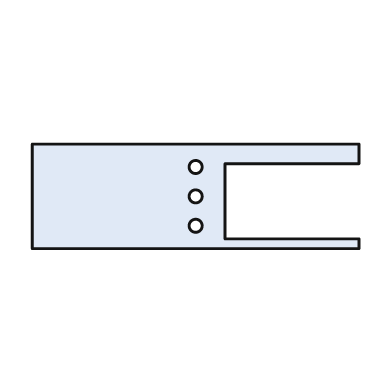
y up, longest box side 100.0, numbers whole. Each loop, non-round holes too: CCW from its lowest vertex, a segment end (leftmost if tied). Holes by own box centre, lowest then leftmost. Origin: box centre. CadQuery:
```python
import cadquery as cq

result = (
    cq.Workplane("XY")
    .moveTo(-50.0, -16.0)
    .lineTo(50.0, -16.0)
    .lineTo(50.0, -13.0)
    .lineTo(9.0, -13.0)
    .lineTo(9.0, 10.0)
    .lineTo(50.0, 10.0)
    .lineTo(50.0, 16.0)
    .lineTo(-50.0, 16.0)
    .close()
    .moveTo(0.0, -9.0)
    .circle(2.0)
    .moveTo(0.0, 0.0)
    .circle(2.0)
    .moveTo(0.0, 9.0)
    .circle(2.0)
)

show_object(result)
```